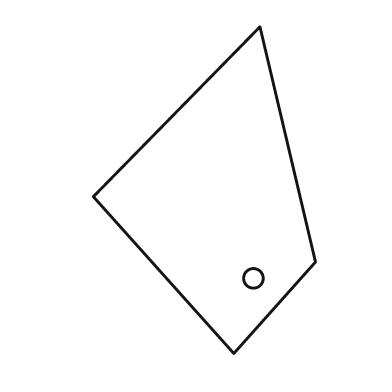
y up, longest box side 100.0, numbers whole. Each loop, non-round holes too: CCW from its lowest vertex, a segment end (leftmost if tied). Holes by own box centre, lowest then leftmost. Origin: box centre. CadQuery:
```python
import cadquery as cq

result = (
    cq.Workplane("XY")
    .moveTo(9.0, -50.0)
    .lineTo(34.0, -22.0)
    .lineTo(17.0, 50.0)
    .lineTo(-34.0, -2.0)
    .close()
    .moveTo(15.0, -27.0)
    .circle(3.0)
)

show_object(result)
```